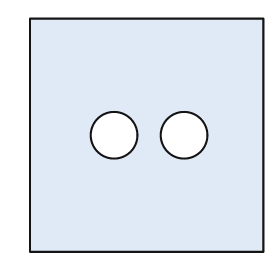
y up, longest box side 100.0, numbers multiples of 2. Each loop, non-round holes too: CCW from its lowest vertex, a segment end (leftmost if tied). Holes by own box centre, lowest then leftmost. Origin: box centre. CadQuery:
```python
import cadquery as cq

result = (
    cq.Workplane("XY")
    .moveTo(-50.0, -50.0)
    .lineTo(50.0, -50.0)
    .lineTo(50.0, 50.0)
    .lineTo(-50.0, 50.0)
    .close()
    .moveTo(-14.0, 0.0)
    .circle(10.0)
    .moveTo(16.0, 0.0)
    .circle(10.0)
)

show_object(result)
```